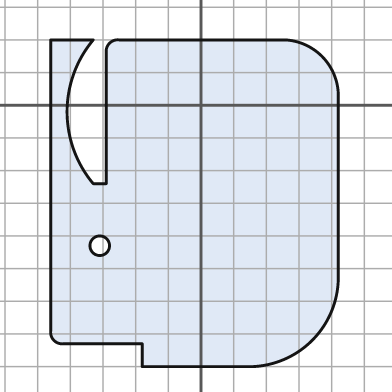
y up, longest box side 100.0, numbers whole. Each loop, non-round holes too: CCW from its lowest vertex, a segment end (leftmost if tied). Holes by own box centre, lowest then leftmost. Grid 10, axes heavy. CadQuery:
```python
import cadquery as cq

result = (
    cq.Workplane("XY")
    .moveTo(-18.0, -80.0)
    .lineTo(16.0, -80.0)
    .threePointArc((34.0, -72.0), (42.0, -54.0))
    .lineTo(42.0, 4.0)
    .threePointArc((37.0, 15.0), (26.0, 20.0))
    .lineTo(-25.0, 20.0)
    .threePointArc((-28.0, 19.0), (-29.0, 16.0))
    .lineTo(-29.0, -24.0)
    .lineTo(-33.0, -24.0)
    .threePointArc((-41.0, -2.0), (-33.0, 20.0))
    .lineTo(-46.0, 20.0)
    .lineTo(-46.0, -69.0)
    .threePointArc((-45.0, -72.0), (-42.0, -73.0))
    .lineTo(-18.0, -73.0)
    .close()
    .moveTo(-31.0, -43.0)
    .circle(3.0)
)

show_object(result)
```